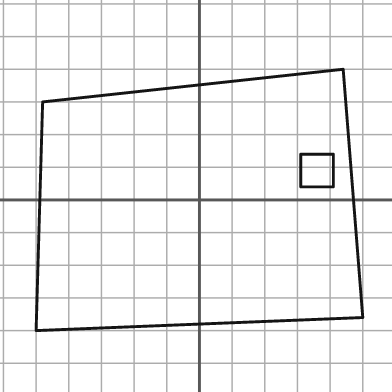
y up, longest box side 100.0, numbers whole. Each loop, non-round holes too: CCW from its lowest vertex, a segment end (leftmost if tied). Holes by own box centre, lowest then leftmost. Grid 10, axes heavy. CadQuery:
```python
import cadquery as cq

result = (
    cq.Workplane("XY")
    .moveTo(-50.0, -40.0)
    .lineTo(50.0, -36.0)
    .lineTo(44.0, 40.0)
    .lineTo(-48.0, 30.0)
    .close()
    .moveTo(31.0, 4.0)
    .lineTo(41.0, 4.0)
    .lineTo(41.0, 14.0)
    .lineTo(31.0, 14.0)
    .close()
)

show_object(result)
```